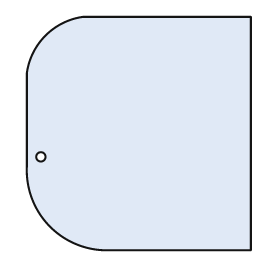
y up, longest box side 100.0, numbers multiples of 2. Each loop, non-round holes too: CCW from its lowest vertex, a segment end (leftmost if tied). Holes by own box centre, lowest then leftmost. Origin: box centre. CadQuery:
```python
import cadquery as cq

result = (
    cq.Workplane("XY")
    .moveTo(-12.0, -50.0)
    .lineTo(48.0, -50.0)
    .lineTo(48.0, 50.0)
    .lineTo(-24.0, 50.0)
    .threePointArc((-40.0, 42.0), (-48.0, 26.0))
    .lineTo(-48.0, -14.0)
    .threePointArc((-38.0, -40.0), (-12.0, -50.0))
    .close()
    .moveTo(-42.0, -10.0)
    .circle(2.0)
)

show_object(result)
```